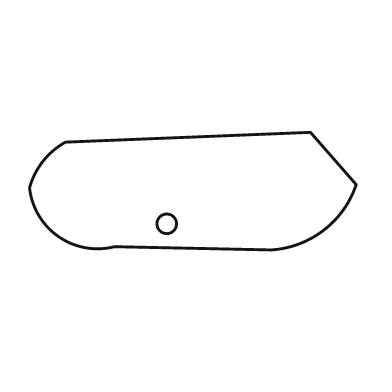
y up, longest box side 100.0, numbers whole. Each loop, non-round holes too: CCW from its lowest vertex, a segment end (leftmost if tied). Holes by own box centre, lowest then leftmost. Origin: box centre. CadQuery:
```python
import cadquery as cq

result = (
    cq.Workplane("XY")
    .moveTo(24.0, -18.0)
    .threePointArc((40.0, -12.0), (50.0, 2.0))
    .lineTo(36.0, 18.0)
    .lineTo(-39.0, 15.0)
    .threePointArc((-46.0, 9.0), (-50.0, 1.0))
    .threePointArc((-41.0, -14.0), (-24.0, -17.0))
    .close()
    .moveTo(-8.0, -10.0)
    .circle(3.0)
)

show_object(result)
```